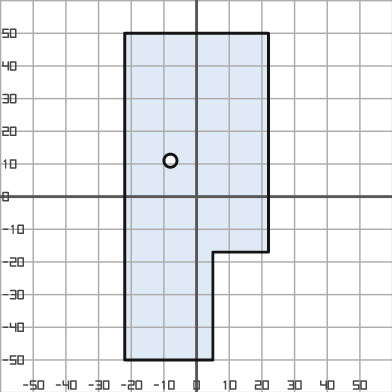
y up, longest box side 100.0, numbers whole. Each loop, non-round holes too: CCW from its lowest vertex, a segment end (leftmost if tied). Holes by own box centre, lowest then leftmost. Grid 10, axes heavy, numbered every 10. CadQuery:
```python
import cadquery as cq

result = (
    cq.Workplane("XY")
    .moveTo(-22.0, -50.0)
    .lineTo(5.0, -50.0)
    .lineTo(5.0, -17.0)
    .lineTo(22.0, -17.0)
    .lineTo(22.0, 50.0)
    .lineTo(-22.0, 50.0)
    .close()
    .moveTo(-8.0, 11.0)
    .circle(2.0)
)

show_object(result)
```